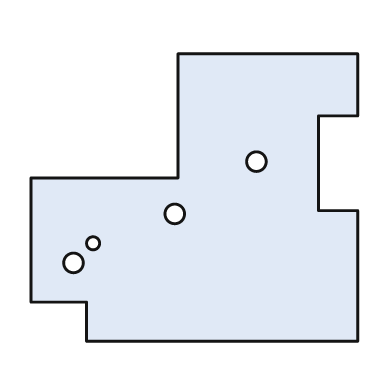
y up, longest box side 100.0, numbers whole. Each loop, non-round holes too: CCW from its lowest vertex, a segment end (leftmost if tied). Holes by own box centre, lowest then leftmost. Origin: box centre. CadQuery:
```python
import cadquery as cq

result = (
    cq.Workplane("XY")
    .moveTo(-33.0, -44.0)
    .lineTo(50.0, -44.0)
    .lineTo(50.0, -4.0)
    .lineTo(38.0, -4.0)
    .lineTo(38.0, 25.0)
    .lineTo(50.0, 25.0)
    .lineTo(50.0, 44.0)
    .lineTo(-5.0, 44.0)
    .lineTo(-5.0, 6.0)
    .lineTo(-50.0, 6.0)
    .lineTo(-50.0, -32.0)
    .lineTo(-33.0, -32.0)
    .close()
    .moveTo(-37.0, -20.0)
    .circle(3.0)
    .moveTo(-31.0, -14.0)
    .circle(2.0)
    .moveTo(-6.0, -5.0)
    .circle(3.0)
    .moveTo(19.0, 11.0)
    .circle(3.0)
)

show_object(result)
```